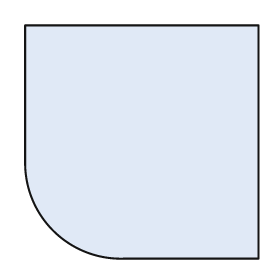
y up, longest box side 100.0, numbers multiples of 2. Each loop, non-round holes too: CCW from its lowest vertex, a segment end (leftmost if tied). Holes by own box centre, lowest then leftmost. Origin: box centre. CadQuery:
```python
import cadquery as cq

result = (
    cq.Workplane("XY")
    .moveTo(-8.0, -50.0)
    .lineTo(50.0, -50.0)
    .lineTo(50.0, 50.0)
    .lineTo(-50.0, 50.0)
    .lineTo(-50.0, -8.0)
    .threePointArc((-38.0, -38.0), (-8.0, -50.0))
    .close()
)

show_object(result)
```